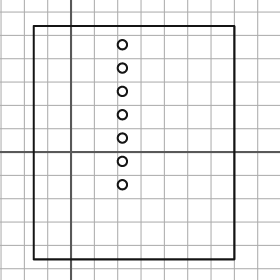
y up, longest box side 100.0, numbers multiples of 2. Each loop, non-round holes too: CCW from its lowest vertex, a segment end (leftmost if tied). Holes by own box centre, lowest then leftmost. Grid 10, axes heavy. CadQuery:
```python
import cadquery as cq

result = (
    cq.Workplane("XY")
    .moveTo(-16.0, -46.0)
    .lineTo(70.0, -46.0)
    .lineTo(70.0, 54.0)
    .lineTo(-16.0, 54.0)
    .close()
    .moveTo(22.0, -14.0)
    .circle(2.0)
    .moveTo(22.0, -4.0)
    .circle(2.0)
    .moveTo(22.0, 6.0)
    .circle(2.0)
    .moveTo(22.0, 16.0)
    .circle(2.0)
    .moveTo(22.0, 26.0)
    .circle(2.0)
    .moveTo(22.0, 36.0)
    .circle(2.0)
    .moveTo(22.0, 46.0)
    .circle(2.0)
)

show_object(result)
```